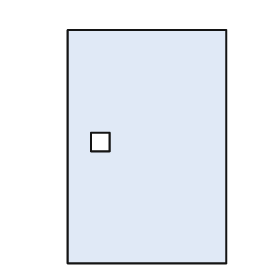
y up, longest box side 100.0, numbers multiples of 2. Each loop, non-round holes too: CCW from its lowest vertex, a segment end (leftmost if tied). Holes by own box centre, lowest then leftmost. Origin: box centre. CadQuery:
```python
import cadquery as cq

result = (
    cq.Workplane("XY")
    .moveTo(-34.0, -50.0)
    .lineTo(34.0, -50.0)
    .lineTo(34.0, 50.0)
    .lineTo(-34.0, 50.0)
    .close()
    .moveTo(-24.0, -2.0)
    .lineTo(-16.0, -2.0)
    .lineTo(-16.0, 6.0)
    .lineTo(-24.0, 6.0)
    .close()
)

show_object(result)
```